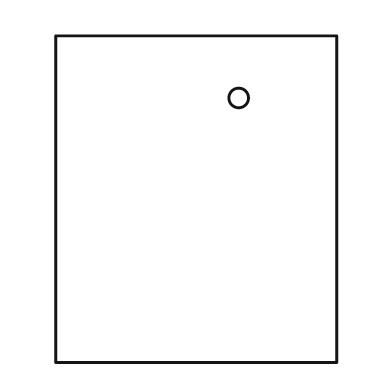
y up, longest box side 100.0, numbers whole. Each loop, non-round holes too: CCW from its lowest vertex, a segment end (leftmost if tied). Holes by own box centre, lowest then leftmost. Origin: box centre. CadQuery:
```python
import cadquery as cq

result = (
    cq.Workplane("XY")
    .moveTo(-43.0, -50.0)
    .lineTo(43.0, -50.0)
    .lineTo(43.0, 50.0)
    .lineTo(-43.0, 50.0)
    .close()
    .moveTo(13.0, 31.0)
    .circle(3.0)
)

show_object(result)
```